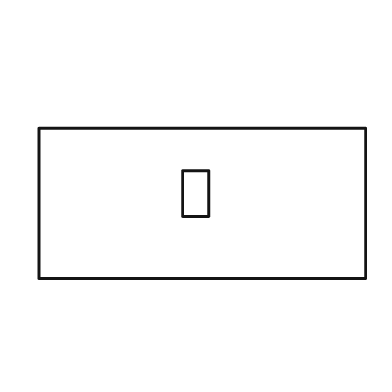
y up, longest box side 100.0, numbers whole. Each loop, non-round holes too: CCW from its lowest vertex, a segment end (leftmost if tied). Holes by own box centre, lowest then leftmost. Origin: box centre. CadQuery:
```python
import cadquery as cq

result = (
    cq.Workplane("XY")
    .moveTo(-50.0, -23.0)
    .lineTo(50.0, -23.0)
    .lineTo(50.0, 23.0)
    .lineTo(-50.0, 23.0)
    .close()
    .moveTo(-6.0, -4.0)
    .lineTo(2.0, -4.0)
    .lineTo(2.0, 10.0)
    .lineTo(-6.0, 10.0)
    .close()
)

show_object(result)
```